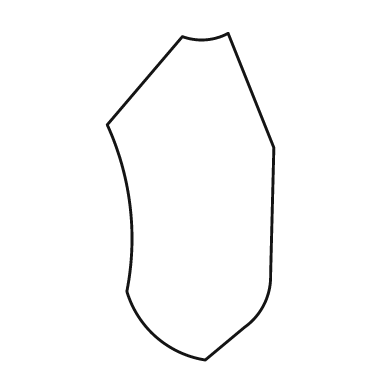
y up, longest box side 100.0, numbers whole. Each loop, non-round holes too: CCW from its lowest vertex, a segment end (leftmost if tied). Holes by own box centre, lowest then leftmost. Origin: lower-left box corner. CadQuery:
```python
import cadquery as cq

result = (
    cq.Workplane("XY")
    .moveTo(30.0, 0.0)
    .lineTo(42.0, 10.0)
    .threePointArc((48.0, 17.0), (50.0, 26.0))
    .lineTo(51.0, 65.0)
    .lineTo(37.0, 100.0)
    .threePointArc((30.0, 98.0), (23.0, 99.0))
    .lineTo(0.0, 72.0)
    .threePointArc((7.0, 47.0), (6.0, 21.0))
    .threePointArc((15.0, 7.0), (30.0, 0.0))
    .close()
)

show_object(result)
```